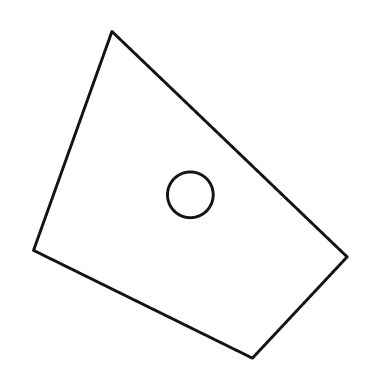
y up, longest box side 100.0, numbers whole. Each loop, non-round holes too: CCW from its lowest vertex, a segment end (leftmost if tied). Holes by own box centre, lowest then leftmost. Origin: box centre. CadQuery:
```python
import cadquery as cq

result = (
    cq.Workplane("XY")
    .moveTo(19.0, -50.0)
    .lineTo(48.0, -19.0)
    .lineTo(-24.0, 50.0)
    .lineTo(-48.0, -17.0)
    .close()
    .moveTo(0.0, 0.0)
    .circle(7.0)
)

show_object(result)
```